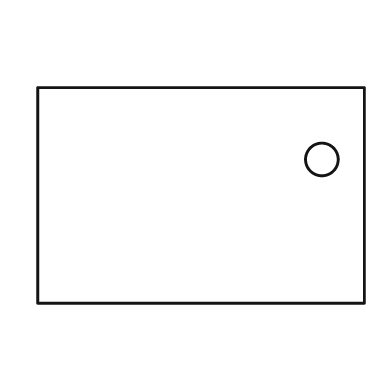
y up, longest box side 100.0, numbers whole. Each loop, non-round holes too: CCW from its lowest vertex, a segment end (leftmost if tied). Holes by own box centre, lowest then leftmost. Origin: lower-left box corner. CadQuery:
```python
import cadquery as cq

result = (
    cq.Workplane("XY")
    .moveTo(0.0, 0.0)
    .lineTo(100.0, 0.0)
    .lineTo(100.0, 66.0)
    .lineTo(0.0, 66.0)
    .close()
    .moveTo(87.0, 44.0)
    .circle(5.0)
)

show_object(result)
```